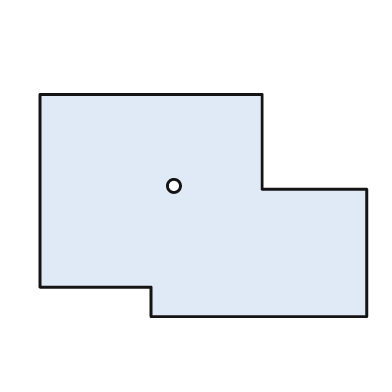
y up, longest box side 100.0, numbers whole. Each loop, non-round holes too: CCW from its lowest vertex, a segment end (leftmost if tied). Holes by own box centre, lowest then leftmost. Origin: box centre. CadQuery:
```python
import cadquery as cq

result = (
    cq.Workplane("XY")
    .moveTo(-16.0, -34.0)
    .lineTo(50.0, -34.0)
    .lineTo(50.0, 5.0)
    .lineTo(18.0, 5.0)
    .lineTo(18.0, 34.0)
    .lineTo(-50.0, 34.0)
    .lineTo(-50.0, -25.0)
    .lineTo(-16.0, -25.0)
    .close()
    .moveTo(-9.0, 6.0)
    .circle(2.0)
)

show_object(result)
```